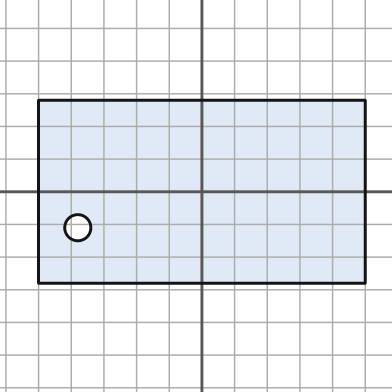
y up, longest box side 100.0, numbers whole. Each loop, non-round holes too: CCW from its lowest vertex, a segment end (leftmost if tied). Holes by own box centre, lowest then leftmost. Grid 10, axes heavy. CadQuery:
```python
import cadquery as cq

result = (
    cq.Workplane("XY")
    .moveTo(-50.0, -28.0)
    .lineTo(50.0, -28.0)
    .lineTo(50.0, 28.0)
    .lineTo(-50.0, 28.0)
    .close()
    .moveTo(-38.0, -11.0)
    .circle(4.0)
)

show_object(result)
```